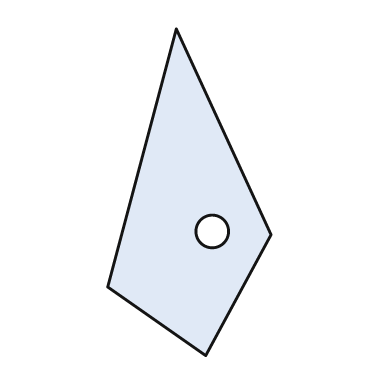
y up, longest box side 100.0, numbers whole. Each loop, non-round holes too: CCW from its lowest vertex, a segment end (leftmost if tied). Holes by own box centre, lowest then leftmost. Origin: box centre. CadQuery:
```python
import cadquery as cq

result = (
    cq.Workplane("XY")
    .moveTo(5.0, -50.0)
    .lineTo(25.0, -13.0)
    .lineTo(-4.0, 50.0)
    .lineTo(-25.0, -29.0)
    .close()
    .moveTo(7.0, -12.0)
    .circle(5.0)
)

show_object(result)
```